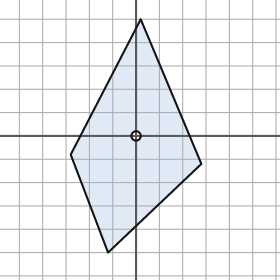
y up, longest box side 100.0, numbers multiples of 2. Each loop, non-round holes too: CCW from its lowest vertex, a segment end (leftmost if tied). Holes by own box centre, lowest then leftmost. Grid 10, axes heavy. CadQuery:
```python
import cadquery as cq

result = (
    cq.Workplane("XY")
    .moveTo(-12.0, -50.0)
    .lineTo(28.0, -12.0)
    .lineTo(2.0, 50.0)
    .lineTo(-28.0, -8.0)
    .close()
    .moveTo(0.0, 0.0)
    .circle(2.0)
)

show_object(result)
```